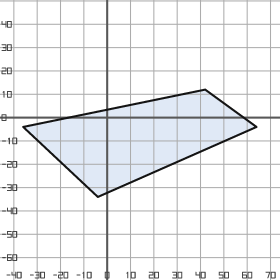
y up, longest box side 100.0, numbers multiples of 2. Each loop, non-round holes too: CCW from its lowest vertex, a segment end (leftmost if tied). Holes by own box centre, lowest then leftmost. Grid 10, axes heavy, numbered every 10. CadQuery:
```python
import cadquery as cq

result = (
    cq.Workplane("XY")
    .moveTo(-4.0, -34.0)
    .lineTo(64.0, -4.0)
    .lineTo(42.0, 12.0)
    .lineTo(-36.0, -4.0)
    .close()
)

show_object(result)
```